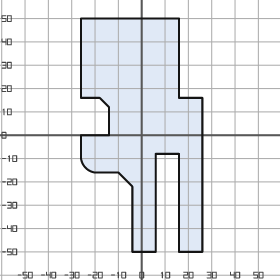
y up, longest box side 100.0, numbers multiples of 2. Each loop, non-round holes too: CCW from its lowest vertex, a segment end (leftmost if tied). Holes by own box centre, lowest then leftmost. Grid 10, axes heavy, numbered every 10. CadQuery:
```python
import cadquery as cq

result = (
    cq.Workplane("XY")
    .moveTo(-4.0, -50.0)
    .lineTo(6.0, -50.0)
    .lineTo(6.0, -8.0)
    .lineTo(16.0, -8.0)
    .lineTo(16.0, -50.0)
    .lineTo(26.0, -50.0)
    .lineTo(26.0, 16.0)
    .lineTo(16.0, 16.0)
    .lineTo(16.0, 50.0)
    .lineTo(-26.0, 50.0)
    .lineTo(-26.0, 16.0)
    .lineTo(-18.0, 16.0)
    .lineTo(-14.0, 12.0)
    .lineTo(-14.0, 0.0)
    .lineTo(-26.0, 0.0)
    .lineTo(-26.0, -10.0)
    .threePointArc((-24.0, -14.0), (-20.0, -16.0))
    .lineTo(-10.0, -16.0)
    .lineTo(-4.0, -22.0)
    .close()
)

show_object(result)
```